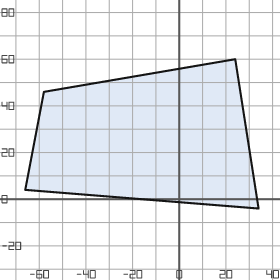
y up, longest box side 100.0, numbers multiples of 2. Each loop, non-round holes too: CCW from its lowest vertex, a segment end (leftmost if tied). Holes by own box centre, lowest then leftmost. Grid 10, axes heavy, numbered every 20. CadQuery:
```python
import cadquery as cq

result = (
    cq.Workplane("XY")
    .moveTo(34.0, -4.0)
    .lineTo(24.0, 60.0)
    .lineTo(-58.0, 46.0)
    .lineTo(-66.0, 4.0)
    .close()
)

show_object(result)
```